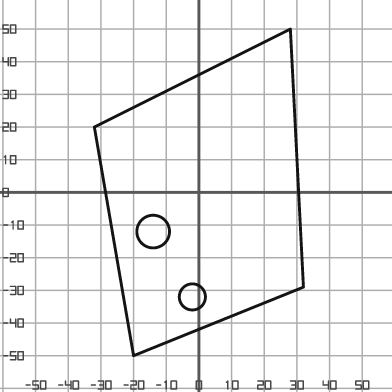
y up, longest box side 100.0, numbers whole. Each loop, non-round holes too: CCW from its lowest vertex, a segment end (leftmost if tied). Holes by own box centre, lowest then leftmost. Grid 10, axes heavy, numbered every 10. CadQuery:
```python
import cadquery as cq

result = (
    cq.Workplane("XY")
    .moveTo(-20.0, -50.0)
    .lineTo(32.0, -29.0)
    .lineTo(28.0, 50.0)
    .lineTo(-32.0, 20.0)
    .close()
    .moveTo(-2.0, -32.0)
    .circle(4.0)
    .moveTo(-14.0, -12.0)
    .circle(5.0)
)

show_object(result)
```